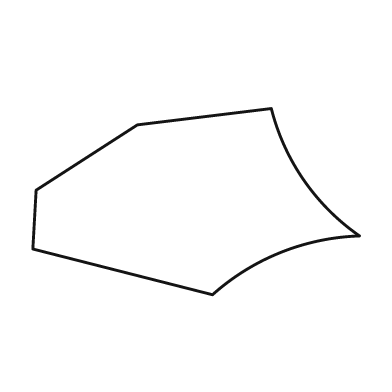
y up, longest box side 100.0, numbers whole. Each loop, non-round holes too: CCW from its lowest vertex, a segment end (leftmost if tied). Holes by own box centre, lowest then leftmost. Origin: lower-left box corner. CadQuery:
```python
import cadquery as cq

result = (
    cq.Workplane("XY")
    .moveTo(55.0, 0.0)
    .threePointArc((76.0, 13.0), (100.0, 18.0))
    .threePointArc((83.0, 35.0), (73.0, 57.0))
    .lineTo(32.0, 52.0)
    .lineTo(1.0, 32.0)
    .lineTo(0.0, 14.0)
    .close()
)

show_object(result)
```